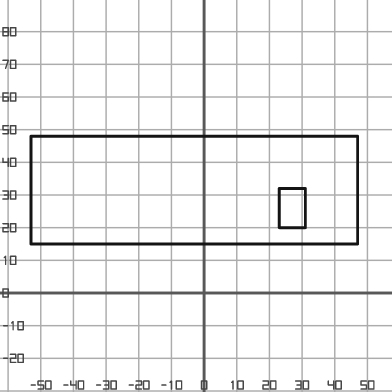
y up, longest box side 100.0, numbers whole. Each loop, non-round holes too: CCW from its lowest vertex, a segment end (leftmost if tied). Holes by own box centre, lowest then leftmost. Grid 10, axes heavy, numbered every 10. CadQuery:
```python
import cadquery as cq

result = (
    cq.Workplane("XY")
    .moveTo(-53.0, 15.0)
    .lineTo(47.0, 15.0)
    .lineTo(47.0, 48.0)
    .lineTo(-53.0, 48.0)
    .close()
    .moveTo(23.0, 20.0)
    .lineTo(31.0, 20.0)
    .lineTo(31.0, 32.0)
    .lineTo(23.0, 32.0)
    .close()
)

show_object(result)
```